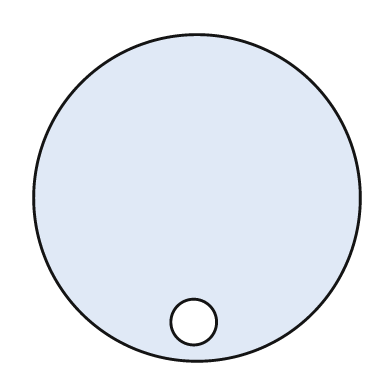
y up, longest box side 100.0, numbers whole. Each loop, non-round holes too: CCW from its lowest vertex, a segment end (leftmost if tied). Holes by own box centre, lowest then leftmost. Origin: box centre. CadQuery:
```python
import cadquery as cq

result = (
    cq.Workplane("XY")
    .moveTo(0.0, 0.0)
    .circle(50.0)
    .moveTo(-1.0, -38.0)
    .circle(7.0)
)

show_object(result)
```